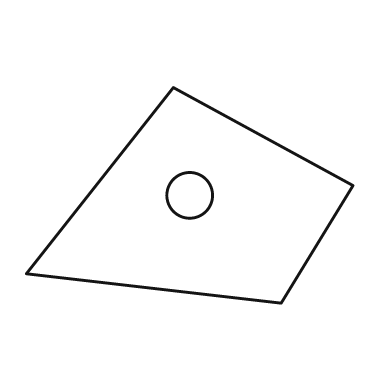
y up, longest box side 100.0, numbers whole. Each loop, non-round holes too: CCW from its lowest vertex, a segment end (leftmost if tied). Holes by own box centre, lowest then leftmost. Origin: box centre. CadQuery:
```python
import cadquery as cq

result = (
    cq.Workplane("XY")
    .moveTo(28.0, -33.0)
    .lineTo(50.0, 3.0)
    .lineTo(-5.0, 33.0)
    .lineTo(-50.0, -24.0)
    .close()
    .moveTo(0.0, 0.0)
    .circle(7.0)
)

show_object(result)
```